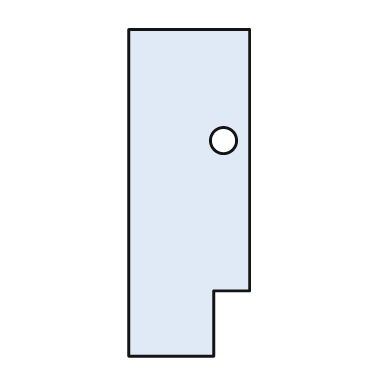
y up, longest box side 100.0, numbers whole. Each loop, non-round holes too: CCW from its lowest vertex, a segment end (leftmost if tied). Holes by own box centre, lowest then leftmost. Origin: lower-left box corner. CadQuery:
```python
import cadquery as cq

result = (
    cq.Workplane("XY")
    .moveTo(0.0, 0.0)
    .lineTo(26.0, 0.0)
    .lineTo(26.0, 20.0)
    .lineTo(37.0, 20.0)
    .lineTo(37.0, 100.0)
    .lineTo(0.0, 100.0)
    .close()
    .moveTo(29.0, 66.0)
    .circle(4.0)
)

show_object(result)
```